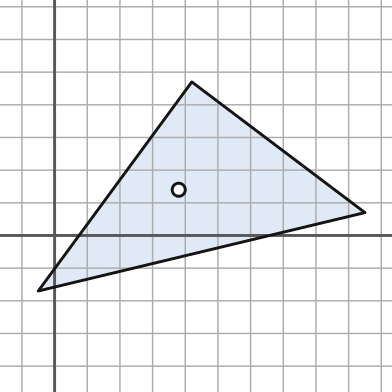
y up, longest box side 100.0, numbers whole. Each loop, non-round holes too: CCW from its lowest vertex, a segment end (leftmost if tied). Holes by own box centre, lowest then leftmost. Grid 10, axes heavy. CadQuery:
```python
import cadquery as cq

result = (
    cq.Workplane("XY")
    .moveTo(-5.0, -17.0)
    .lineTo(95.0, 7.0)
    .lineTo(42.0, 47.0)
    .close()
    .moveTo(38.0, 14.0)
    .circle(2.0)
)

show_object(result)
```